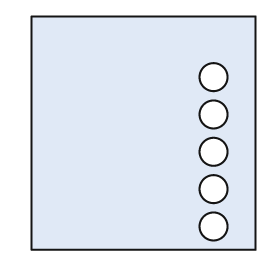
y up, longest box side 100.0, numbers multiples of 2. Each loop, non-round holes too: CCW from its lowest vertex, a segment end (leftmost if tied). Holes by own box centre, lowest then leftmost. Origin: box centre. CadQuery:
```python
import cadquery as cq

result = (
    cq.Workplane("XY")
    .moveTo(-48.0, -50.0)
    .lineTo(48.0, -50.0)
    .lineTo(48.0, 50.0)
    .lineTo(-48.0, 50.0)
    .close()
    .moveTo(30.0, -40.0)
    .circle(6.0)
    .moveTo(30.0, -24.0)
    .circle(6.0)
    .moveTo(30.0, -8.0)
    .circle(6.0)
    .moveTo(30.0, 8.0)
    .circle(6.0)
    .moveTo(30.0, 24.0)
    .circle(6.0)
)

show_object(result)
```